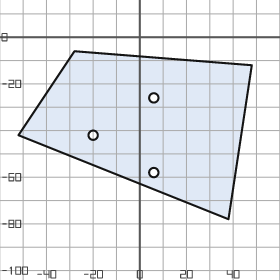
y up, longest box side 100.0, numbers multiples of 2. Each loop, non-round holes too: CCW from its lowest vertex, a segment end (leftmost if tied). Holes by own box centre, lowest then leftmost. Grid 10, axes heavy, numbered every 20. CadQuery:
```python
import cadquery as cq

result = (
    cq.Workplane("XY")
    .moveTo(38.0, -78.0)
    .lineTo(48.0, -12.0)
    .lineTo(-28.0, -6.0)
    .lineTo(-52.0, -42.0)
    .close()
    .moveTo(6.0, -58.0)
    .circle(2.0)
    .moveTo(-20.0, -42.0)
    .circle(2.0)
    .moveTo(6.0, -26.0)
    .circle(2.0)
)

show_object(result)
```